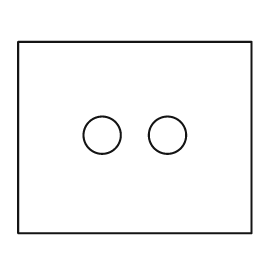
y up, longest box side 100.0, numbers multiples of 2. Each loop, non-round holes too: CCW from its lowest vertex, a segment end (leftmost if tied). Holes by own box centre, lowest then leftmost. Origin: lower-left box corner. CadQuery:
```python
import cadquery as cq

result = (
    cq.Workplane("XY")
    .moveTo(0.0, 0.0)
    .lineTo(100.0, 0.0)
    .lineTo(100.0, 82.0)
    .lineTo(0.0, 82.0)
    .close()
    .moveTo(36.0, 42.0)
    .circle(8.0)
    .moveTo(64.0, 42.0)
    .circle(8.0)
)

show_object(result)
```